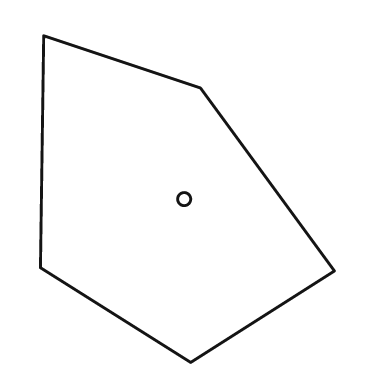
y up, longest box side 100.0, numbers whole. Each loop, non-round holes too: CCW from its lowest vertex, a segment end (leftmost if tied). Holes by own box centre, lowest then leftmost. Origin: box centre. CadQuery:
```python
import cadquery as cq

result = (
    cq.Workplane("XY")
    .moveTo(1.0, -50.0)
    .lineTo(45.0, -22.0)
    .lineTo(4.0, 34.0)
    .lineTo(-44.0, 50.0)
    .lineTo(-45.0, -21.0)
    .close()
    .moveTo(-1.0, 0.0)
    .circle(2.0)
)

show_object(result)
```